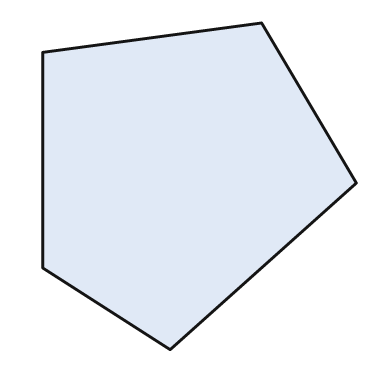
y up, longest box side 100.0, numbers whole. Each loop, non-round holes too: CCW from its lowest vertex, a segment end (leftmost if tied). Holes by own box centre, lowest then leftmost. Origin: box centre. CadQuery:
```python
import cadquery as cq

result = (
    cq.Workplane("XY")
    .moveTo(-9.0, -50.0)
    .lineTo(48.0, 1.0)
    .lineTo(19.0, 50.0)
    .lineTo(-48.0, 41.0)
    .lineTo(-48.0, -25.0)
    .close()
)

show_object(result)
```